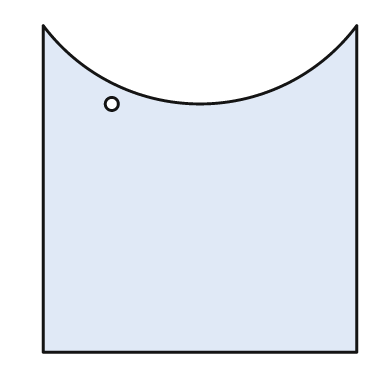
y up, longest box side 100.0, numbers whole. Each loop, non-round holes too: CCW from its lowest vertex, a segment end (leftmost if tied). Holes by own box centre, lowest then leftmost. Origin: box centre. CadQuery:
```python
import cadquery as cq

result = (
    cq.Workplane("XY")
    .moveTo(-48.0, -50.0)
    .lineTo(48.0, -50.0)
    .lineTo(48.0, 50.0)
    .threePointArc((0.0, 26.0), (-48.0, 50.0))
    .close()
    .moveTo(-27.0, 26.0)
    .circle(2.0)
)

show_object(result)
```